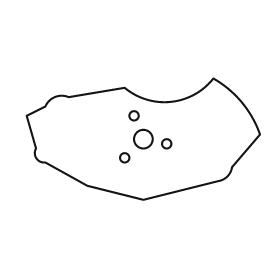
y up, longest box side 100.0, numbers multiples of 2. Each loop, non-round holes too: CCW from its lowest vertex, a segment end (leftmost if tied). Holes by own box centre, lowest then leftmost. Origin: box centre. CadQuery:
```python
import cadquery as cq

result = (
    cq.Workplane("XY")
    .moveTo(0.0, -26.0)
    .lineTo(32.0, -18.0)
    .threePointArc((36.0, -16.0), (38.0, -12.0))
    .lineTo(50.0, 2.0)
    .threePointArc((42.0, 16.0), (30.0, 26.0))
    .threePointArc((12.0, 16.0), (-8.0, 22.0))
    .lineTo(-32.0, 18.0)
    .threePointArc((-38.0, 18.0), (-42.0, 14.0))
    .lineTo(-50.0, 10.0)
    .lineTo(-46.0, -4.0)
    .threePointArc((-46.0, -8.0), (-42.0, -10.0))
    .lineTo(-24.0, -20.0)
    .close()
    .moveTo(-8.0, -8.0)
    .circle(2.0)
    .moveTo(10.0, -2.0)
    .circle(2.0)
    .moveTo(0.0, 0.0)
    .circle(4.0)
    .moveTo(-4.0, 10.0)
    .circle(2.0)
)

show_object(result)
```